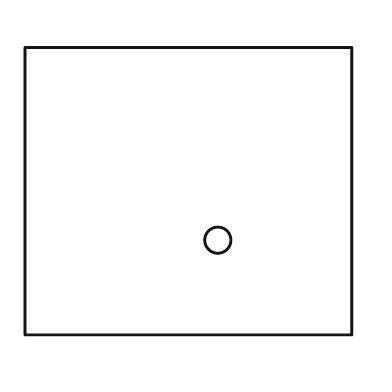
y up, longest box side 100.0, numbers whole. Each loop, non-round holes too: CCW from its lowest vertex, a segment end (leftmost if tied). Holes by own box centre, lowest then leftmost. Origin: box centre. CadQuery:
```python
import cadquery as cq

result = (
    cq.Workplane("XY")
    .moveTo(-50.0, -44.0)
    .lineTo(50.0, -44.0)
    .lineTo(50.0, 44.0)
    .lineTo(-50.0, 44.0)
    .close()
    .moveTo(9.0, -15.0)
    .circle(4.0)
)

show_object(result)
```